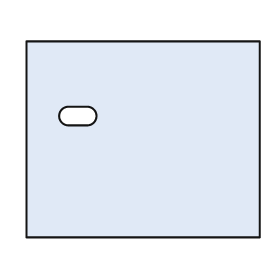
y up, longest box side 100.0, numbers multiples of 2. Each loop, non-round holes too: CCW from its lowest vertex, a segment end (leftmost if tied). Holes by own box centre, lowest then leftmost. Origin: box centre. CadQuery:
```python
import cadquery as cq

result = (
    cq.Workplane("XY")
    .moveTo(-50.0, -42.0)
    .lineTo(50.0, -42.0)
    .lineTo(50.0, 42.0)
    .lineTo(-50.0, 42.0)
    .close()
    .moveTo(-32.0, 6.0)
    .lineTo(-24.0, 6.0)
    .threePointArc((-20.0, 10.0), (-24.0, 14.0))
    .lineTo(-32.0, 14.0)
    .threePointArc((-36.0, 10.0), (-32.0, 6.0))
    .close()
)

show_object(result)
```